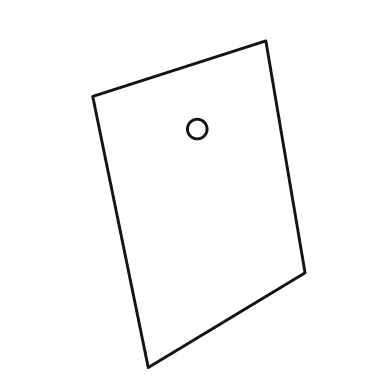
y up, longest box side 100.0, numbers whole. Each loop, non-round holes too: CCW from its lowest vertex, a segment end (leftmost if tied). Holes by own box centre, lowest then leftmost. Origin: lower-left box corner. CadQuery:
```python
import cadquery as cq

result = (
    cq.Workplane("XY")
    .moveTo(17.0, 0.0)
    .lineTo(65.0, 29.0)
    .lineTo(53.0, 100.0)
    .lineTo(0.0, 83.0)
    .close()
    .moveTo(32.0, 73.0)
    .circle(3.0)
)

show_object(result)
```